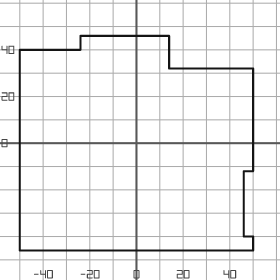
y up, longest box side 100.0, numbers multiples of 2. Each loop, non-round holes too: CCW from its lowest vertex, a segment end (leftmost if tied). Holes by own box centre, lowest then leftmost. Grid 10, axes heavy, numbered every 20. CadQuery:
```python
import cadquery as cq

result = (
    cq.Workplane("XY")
    .moveTo(-50.0, -46.0)
    .lineTo(50.0, -46.0)
    .lineTo(50.0, -40.0)
    .lineTo(46.0, -40.0)
    .lineTo(46.0, -12.0)
    .lineTo(50.0, -12.0)
    .lineTo(50.0, 32.0)
    .lineTo(14.0, 32.0)
    .lineTo(14.0, 46.0)
    .lineTo(-24.0, 46.0)
    .lineTo(-24.0, 40.0)
    .lineTo(-50.0, 40.0)
    .close()
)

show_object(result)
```